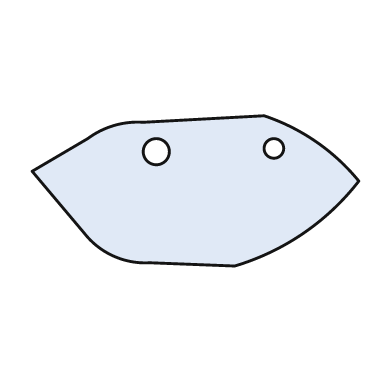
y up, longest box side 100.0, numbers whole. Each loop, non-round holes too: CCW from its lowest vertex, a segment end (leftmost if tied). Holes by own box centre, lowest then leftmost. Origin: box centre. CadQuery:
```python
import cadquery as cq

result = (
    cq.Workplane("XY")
    .moveTo(12.0, -23.0)
    .threePointArc((33.0, -13.0), (50.0, 3.0))
    .threePointArc((37.0, 15.0), (21.0, 23.0))
    .lineTo(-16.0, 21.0)
    .threePointArc((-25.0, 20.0), (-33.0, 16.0))
    .lineTo(-50.0, 6.0)
    .lineTo(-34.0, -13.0)
    .threePointArc((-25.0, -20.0), (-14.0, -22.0))
    .close()
    .moveTo(-12.0, 12.0)
    .circle(4.0)
    .moveTo(24.0, 13.0)
    .circle(3.0)
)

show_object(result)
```